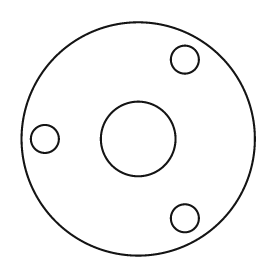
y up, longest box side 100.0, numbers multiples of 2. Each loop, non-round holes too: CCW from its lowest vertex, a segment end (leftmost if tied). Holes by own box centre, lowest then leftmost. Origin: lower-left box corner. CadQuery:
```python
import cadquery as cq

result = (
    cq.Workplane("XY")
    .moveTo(50.0, 50.0)
    .circle(50.0)
    .moveTo(70.0, 16.0)
    .circle(6.0)
    .moveTo(10.0, 50.0)
    .circle(6.0)
    .moveTo(50.0, 50.0)
    .circle(16.0)
    .moveTo(70.0, 84.0)
    .circle(6.0)
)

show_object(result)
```